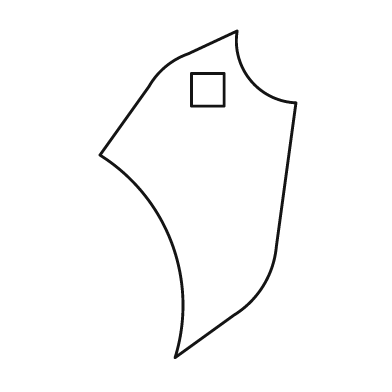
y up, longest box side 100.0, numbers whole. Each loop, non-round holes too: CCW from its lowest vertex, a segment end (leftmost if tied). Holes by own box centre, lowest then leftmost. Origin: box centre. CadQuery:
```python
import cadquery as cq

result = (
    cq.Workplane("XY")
    .moveTo(-7.0, -50.0)
    .lineTo(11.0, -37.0)
    .threePointArc((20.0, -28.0), (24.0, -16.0))
    .lineTo(30.0, 28.0)
    .threePointArc((16.0, 35.0), (12.0, 50.0))
    .lineTo(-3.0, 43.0)
    .threePointArc((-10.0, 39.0), (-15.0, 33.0))
    .lineTo(-30.0, 12.0)
    .threePointArc((-8.0, -15.0), (-7.0, -50.0))
    .close()
    .moveTo(-2.0, 27.0)
    .lineTo(8.0, 27.0)
    .lineTo(8.0, 37.0)
    .lineTo(-2.0, 37.0)
    .close()
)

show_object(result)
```